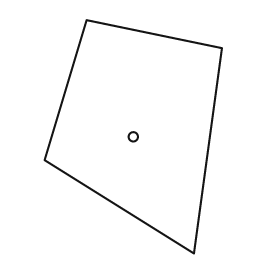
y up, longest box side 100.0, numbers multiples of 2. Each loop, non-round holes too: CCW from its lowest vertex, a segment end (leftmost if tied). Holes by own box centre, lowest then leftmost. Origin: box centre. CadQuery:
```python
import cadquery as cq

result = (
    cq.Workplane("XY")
    .moveTo(26.0, -50.0)
    .lineTo(38.0, 38.0)
    .lineTo(-20.0, 50.0)
    .lineTo(-38.0, -10.0)
    .close()
    .moveTo(0.0, 0.0)
    .circle(2.0)
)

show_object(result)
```